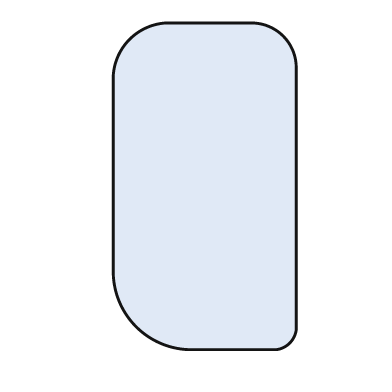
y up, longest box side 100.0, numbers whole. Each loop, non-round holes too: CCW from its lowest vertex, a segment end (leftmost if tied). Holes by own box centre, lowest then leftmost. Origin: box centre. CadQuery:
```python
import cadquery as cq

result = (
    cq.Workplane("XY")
    .moveTo(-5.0, -50.0)
    .lineTo(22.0, -50.0)
    .threePointArc((26.0, -48.0), (28.0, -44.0))
    .lineTo(28.0, 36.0)
    .threePointArc((24.0, 46.0), (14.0, 50.0))
    .lineTo(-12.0, 50.0)
    .threePointArc((-23.0, 45.0), (-28.0, 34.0))
    .lineTo(-28.0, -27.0)
    .threePointArc((-21.0, -43.0), (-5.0, -50.0))
    .close()
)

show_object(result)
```